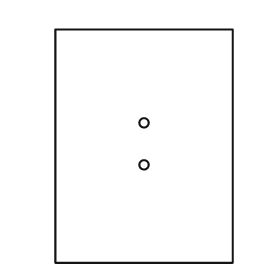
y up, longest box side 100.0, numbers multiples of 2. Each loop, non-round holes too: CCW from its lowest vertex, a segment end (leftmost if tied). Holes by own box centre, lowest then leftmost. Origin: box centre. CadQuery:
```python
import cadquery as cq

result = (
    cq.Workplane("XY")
    .moveTo(-38.0, -50.0)
    .lineTo(38.0, -50.0)
    .lineTo(38.0, 50.0)
    .lineTo(-38.0, 50.0)
    .close()
    .moveTo(0.0, -8.0)
    .circle(2.0)
    .moveTo(0.0, 10.0)
    .circle(2.0)
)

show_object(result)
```